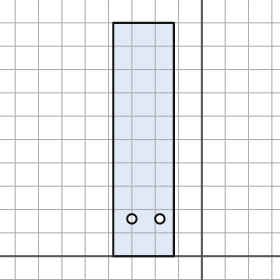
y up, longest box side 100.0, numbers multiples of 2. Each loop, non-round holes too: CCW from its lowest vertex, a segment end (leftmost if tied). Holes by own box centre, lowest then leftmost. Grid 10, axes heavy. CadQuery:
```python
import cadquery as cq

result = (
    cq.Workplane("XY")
    .moveTo(-38.0, 0.0)
    .lineTo(-12.0, 0.0)
    .lineTo(-12.0, 100.0)
    .lineTo(-38.0, 100.0)
    .close()
    .moveTo(-30.0, 16.0)
    .circle(2.0)
    .moveTo(-18.0, 16.0)
    .circle(2.0)
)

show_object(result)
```